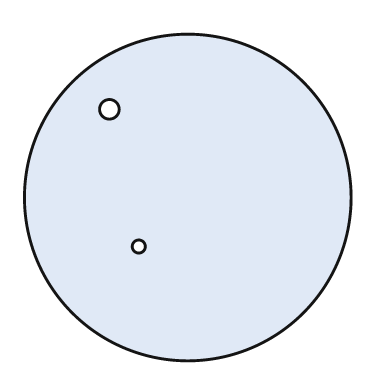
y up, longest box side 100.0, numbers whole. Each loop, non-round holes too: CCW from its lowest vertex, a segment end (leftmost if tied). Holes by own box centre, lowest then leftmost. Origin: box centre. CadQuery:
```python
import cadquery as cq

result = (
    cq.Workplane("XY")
    .moveTo(0.0, 0.0)
    .circle(50.0)
    .moveTo(-15.0, -15.0)
    .circle(2.0)
    .moveTo(-24.0, 27.0)
    .circle(3.0)
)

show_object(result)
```